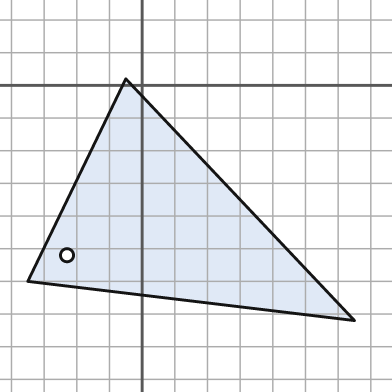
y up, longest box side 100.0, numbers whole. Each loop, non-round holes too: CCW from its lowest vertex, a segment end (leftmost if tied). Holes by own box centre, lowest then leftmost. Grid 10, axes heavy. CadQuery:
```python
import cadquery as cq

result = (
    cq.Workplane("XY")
    .moveTo(65.0, -72.0)
    .lineTo(-5.0, 2.0)
    .lineTo(-35.0, -60.0)
    .close()
    .moveTo(-23.0, -52.0)
    .circle(2.0)
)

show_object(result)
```